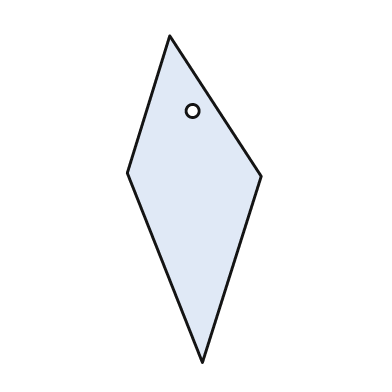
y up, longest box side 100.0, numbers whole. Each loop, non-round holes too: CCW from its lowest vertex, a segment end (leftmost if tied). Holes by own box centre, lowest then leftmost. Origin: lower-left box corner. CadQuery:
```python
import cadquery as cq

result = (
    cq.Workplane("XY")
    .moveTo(23.0, 0.0)
    .lineTo(41.0, 57.0)
    .lineTo(13.0, 100.0)
    .lineTo(0.0, 58.0)
    .close()
    .moveTo(20.0, 77.0)
    .circle(2.0)
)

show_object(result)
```